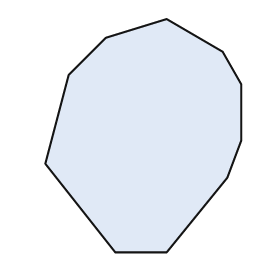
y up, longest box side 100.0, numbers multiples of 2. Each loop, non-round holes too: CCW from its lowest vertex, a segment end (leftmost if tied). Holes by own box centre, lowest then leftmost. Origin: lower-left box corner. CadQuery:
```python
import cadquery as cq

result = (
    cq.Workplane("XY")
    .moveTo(30.0, 0.0)
    .lineTo(52.0, 0.0)
    .lineTo(78.0, 32.0)
    .lineTo(84.0, 48.0)
    .lineTo(84.0, 72.0)
    .lineTo(76.0, 86.0)
    .lineTo(52.0, 100.0)
    .lineTo(26.0, 92.0)
    .lineTo(10.0, 76.0)
    .lineTo(0.0, 38.0)
    .close()
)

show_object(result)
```